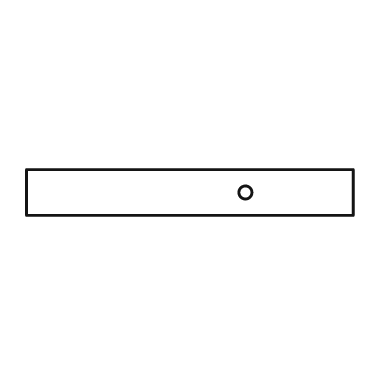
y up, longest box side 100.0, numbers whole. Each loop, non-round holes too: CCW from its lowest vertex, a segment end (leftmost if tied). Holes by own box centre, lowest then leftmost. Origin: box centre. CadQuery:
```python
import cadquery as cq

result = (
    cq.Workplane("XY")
    .moveTo(-50.0, -7.0)
    .lineTo(50.0, -7.0)
    .lineTo(50.0, 7.0)
    .lineTo(-50.0, 7.0)
    .close()
    .moveTo(17.0, 0.0)
    .circle(2.0)
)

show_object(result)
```